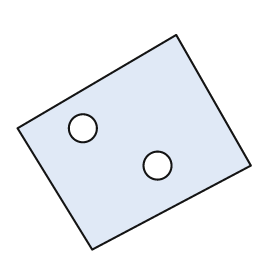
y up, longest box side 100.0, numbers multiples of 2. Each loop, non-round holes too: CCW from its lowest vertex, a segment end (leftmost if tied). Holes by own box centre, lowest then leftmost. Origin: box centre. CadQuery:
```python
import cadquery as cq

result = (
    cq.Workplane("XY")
    .moveTo(-18.0, -46.0)
    .lineTo(50.0, -10.0)
    .lineTo(18.0, 46.0)
    .lineTo(-50.0, 6.0)
    .close()
    .moveTo(10.0, -10.0)
    .circle(6.0)
    .moveTo(-22.0, 6.0)
    .circle(6.0)
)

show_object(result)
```